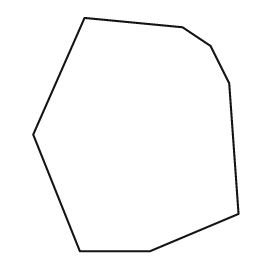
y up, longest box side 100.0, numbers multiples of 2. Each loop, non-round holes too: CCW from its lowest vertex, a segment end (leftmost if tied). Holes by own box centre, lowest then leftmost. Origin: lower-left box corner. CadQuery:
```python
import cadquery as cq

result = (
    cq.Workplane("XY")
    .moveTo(20.0, 0.0)
    .lineTo(50.0, 0.0)
    .lineTo(88.0, 16.0)
    .lineTo(84.0, 72.0)
    .lineTo(76.0, 88.0)
    .lineTo(64.0, 96.0)
    .lineTo(22.0, 100.0)
    .lineTo(0.0, 50.0)
    .close()
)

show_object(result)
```